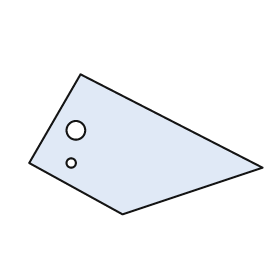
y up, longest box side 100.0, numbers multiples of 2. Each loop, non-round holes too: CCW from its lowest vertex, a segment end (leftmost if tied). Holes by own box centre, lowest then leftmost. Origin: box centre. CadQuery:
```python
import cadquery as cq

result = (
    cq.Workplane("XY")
    .moveTo(-10.0, -30.0)
    .lineTo(50.0, -10.0)
    .lineTo(-28.0, 30.0)
    .lineTo(-50.0, -8.0)
    .close()
    .moveTo(-32.0, -8.0)
    .circle(2.0)
    .moveTo(-30.0, 6.0)
    .circle(4.0)
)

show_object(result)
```